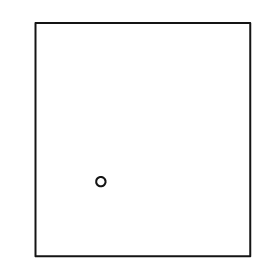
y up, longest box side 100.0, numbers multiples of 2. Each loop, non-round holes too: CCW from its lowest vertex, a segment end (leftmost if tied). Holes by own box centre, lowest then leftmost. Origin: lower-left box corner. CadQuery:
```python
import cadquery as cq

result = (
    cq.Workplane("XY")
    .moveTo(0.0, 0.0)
    .lineTo(92.0, 0.0)
    .lineTo(92.0, 100.0)
    .lineTo(0.0, 100.0)
    .close()
    .moveTo(28.0, 32.0)
    .circle(2.0)
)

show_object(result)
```